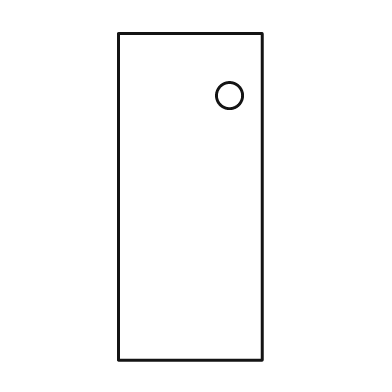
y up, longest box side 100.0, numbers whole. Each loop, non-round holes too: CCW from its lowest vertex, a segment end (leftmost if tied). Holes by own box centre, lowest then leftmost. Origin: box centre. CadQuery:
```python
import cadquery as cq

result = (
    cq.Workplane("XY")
    .moveTo(-22.0, -50.0)
    .lineTo(22.0, -50.0)
    .lineTo(22.0, 50.0)
    .lineTo(-22.0, 50.0)
    .close()
    .moveTo(12.0, 31.0)
    .circle(4.0)
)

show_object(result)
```